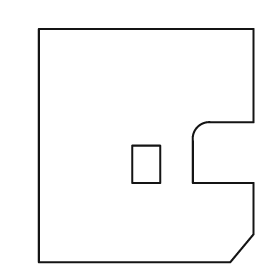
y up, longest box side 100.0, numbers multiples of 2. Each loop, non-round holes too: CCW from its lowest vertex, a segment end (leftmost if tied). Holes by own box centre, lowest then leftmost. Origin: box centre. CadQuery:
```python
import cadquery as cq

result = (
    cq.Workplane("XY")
    .moveTo(-46.0, -50.0)
    .lineTo(36.0, -50.0)
    .lineTo(46.0, -38.0)
    .lineTo(46.0, -16.0)
    .lineTo(20.0, -16.0)
    .lineTo(20.0, 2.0)
    .threePointArc((22.0, 8.0), (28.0, 10.0))
    .lineTo(46.0, 10.0)
    .lineTo(46.0, 50.0)
    .lineTo(-46.0, 50.0)
    .close()
    .moveTo(-6.0, -16.0)
    .lineTo(6.0, -16.0)
    .lineTo(6.0, 0.0)
    .lineTo(-6.0, 0.0)
    .close()
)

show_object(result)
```